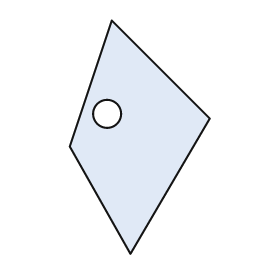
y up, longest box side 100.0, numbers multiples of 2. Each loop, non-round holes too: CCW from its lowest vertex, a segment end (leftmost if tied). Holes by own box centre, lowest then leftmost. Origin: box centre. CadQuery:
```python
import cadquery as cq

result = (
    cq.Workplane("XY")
    .moveTo(-4.0, -50.0)
    .lineTo(30.0, 8.0)
    .lineTo(-12.0, 50.0)
    .lineTo(-30.0, -4.0)
    .close()
    .moveTo(-14.0, 10.0)
    .circle(6.0)
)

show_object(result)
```